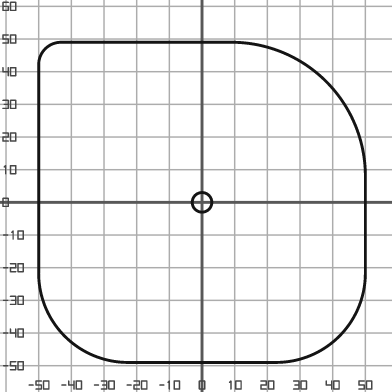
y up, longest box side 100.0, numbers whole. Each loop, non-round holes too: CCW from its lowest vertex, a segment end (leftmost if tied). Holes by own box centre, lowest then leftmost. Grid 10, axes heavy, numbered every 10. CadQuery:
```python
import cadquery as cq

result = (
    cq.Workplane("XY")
    .moveTo(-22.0, -49.0)
    .lineTo(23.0, -49.0)
    .threePointArc((42.0, -41.0), (50.0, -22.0))
    .lineTo(50.0, 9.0)
    .threePointArc((38.0, 37.0), (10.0, 49.0))
    .lineTo(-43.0, 49.0)
    .threePointArc((-48.0, 47.0), (-50.0, 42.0))
    .lineTo(-50.0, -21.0)
    .threePointArc((-42.0, -41.0), (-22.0, -49.0))
    .close()
    .moveTo(0.0, 0.0)
    .circle(3.0)
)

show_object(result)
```